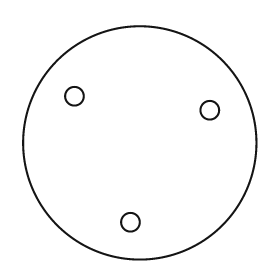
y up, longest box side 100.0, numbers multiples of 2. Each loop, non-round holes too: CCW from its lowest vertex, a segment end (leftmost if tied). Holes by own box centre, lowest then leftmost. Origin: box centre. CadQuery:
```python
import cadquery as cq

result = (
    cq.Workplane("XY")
    .moveTo(0.0, 0.0)
    .circle(50.0)
    .moveTo(-4.0, -34.0)
    .circle(4.0)
    .moveTo(30.0, 14.0)
    .circle(4.0)
    .moveTo(-28.0, 20.0)
    .circle(4.0)
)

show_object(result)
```